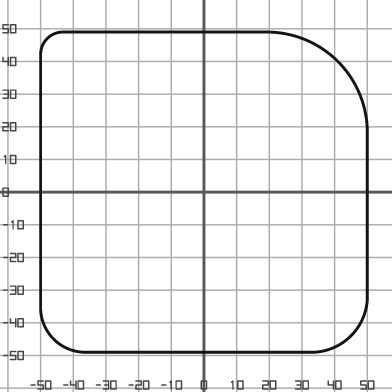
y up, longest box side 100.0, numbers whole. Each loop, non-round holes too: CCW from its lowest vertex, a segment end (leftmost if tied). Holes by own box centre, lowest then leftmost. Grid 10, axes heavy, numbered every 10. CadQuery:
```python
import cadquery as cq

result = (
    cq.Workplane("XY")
    .moveTo(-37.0, -49.0)
    .lineTo(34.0, -49.0)
    .threePointArc((45.0, -44.0), (50.0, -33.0))
    .lineTo(50.0, 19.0)
    .threePointArc((41.0, 40.0), (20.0, 49.0))
    .lineTo(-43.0, 49.0)
    .threePointArc((-48.0, 47.0), (-50.0, 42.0))
    .lineTo(-50.0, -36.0)
    .threePointArc((-46.0, -45.0), (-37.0, -49.0))
    .close()
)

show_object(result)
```